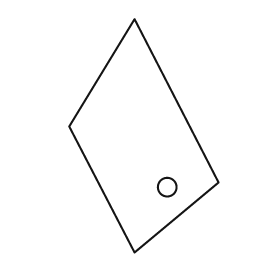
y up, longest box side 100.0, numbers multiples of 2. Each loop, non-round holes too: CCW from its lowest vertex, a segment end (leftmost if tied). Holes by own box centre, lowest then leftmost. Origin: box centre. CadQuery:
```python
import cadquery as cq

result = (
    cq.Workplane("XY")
    .moveTo(-4.0, -50.0)
    .lineTo(32.0, -20.0)
    .lineTo(-4.0, 50.0)
    .lineTo(-32.0, 4.0)
    .close()
    .moveTo(10.0, -22.0)
    .circle(4.0)
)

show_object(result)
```